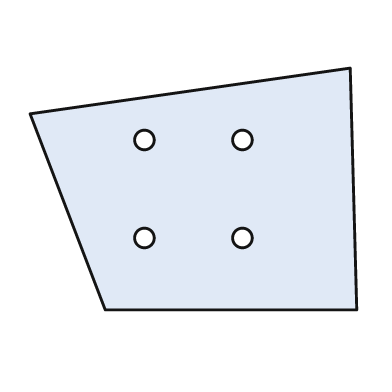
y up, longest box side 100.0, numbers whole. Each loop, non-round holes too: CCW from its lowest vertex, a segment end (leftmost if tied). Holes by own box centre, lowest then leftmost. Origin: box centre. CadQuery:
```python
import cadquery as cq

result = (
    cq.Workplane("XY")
    .moveTo(-27.0, -37.0)
    .lineTo(50.0, -37.0)
    .lineTo(48.0, 37.0)
    .lineTo(-50.0, 23.0)
    .close()
    .moveTo(-15.0, -15.0)
    .circle(3.0)
    .moveTo(15.0, -15.0)
    .circle(3.0)
    .moveTo(-15.0, 15.0)
    .circle(3.0)
    .moveTo(15.0, 15.0)
    .circle(3.0)
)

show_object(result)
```